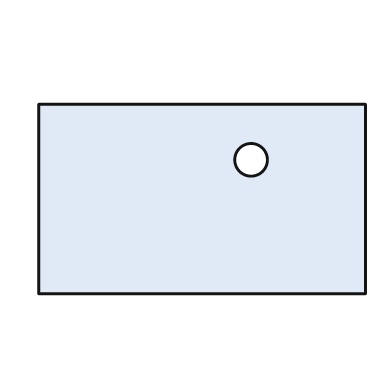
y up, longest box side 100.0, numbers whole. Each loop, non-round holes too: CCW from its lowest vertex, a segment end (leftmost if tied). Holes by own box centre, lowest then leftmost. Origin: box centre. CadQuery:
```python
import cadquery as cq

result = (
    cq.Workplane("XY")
    .moveTo(-50.0, -29.0)
    .lineTo(50.0, -29.0)
    .lineTo(50.0, 29.0)
    .lineTo(-50.0, 29.0)
    .close()
    .moveTo(15.0, 12.0)
    .circle(5.0)
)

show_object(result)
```